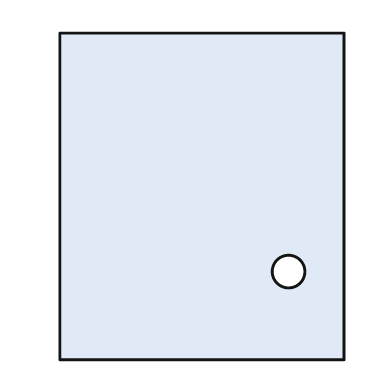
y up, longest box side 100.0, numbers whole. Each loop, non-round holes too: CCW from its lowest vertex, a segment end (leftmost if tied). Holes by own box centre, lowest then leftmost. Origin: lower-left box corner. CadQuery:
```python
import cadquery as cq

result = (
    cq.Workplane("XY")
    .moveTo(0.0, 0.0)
    .lineTo(87.0, 0.0)
    .lineTo(87.0, 100.0)
    .lineTo(0.0, 100.0)
    .close()
    .moveTo(70.0, 27.0)
    .circle(5.0)
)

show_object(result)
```